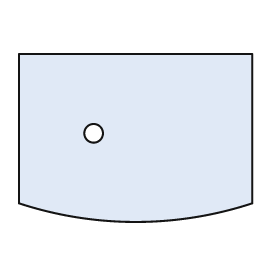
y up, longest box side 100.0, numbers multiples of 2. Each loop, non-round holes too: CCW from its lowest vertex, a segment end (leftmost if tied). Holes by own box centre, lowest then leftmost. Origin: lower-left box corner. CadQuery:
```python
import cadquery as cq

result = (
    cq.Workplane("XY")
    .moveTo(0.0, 8.0)
    .threePointArc((50.0, 0.0), (100.0, 8.0))
    .lineTo(100.0, 72.0)
    .lineTo(0.0, 72.0)
    .close()
    .moveTo(32.0, 38.0)
    .circle(4.0)
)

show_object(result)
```